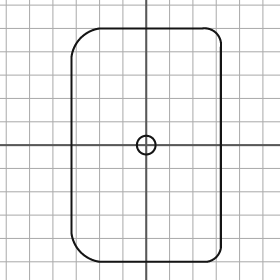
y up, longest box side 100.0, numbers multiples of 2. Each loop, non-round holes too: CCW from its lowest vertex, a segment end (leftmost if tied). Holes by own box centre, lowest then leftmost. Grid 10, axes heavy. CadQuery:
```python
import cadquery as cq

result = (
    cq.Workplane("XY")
    .moveTo(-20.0, -50.0)
    .lineTo(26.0, -50.0)
    .threePointArc((30.0, -48.0), (32.0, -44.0))
    .lineTo(32.0, 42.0)
    .threePointArc((30.0, 48.0), (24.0, 50.0))
    .lineTo(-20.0, 50.0)
    .threePointArc((-28.0, 46.0), (-32.0, 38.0))
    .lineTo(-32.0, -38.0)
    .threePointArc((-28.0, -46.0), (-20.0, -50.0))
    .close()
    .moveTo(0.0, 0.0)
    .circle(4.0)
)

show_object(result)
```